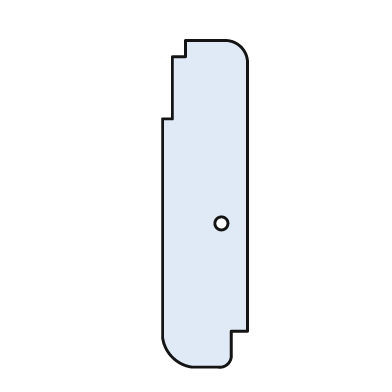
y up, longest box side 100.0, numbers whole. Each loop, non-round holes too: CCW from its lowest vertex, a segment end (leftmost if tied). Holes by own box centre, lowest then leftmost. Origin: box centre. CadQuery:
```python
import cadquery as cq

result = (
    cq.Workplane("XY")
    .moveTo(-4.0, -50.0)
    .lineTo(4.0, -50.0)
    .threePointArc((7.0, -49.0), (8.0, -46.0))
    .lineTo(8.0, -39.0)
    .lineTo(13.0, -39.0)
    .lineTo(13.0, 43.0)
    .threePointArc((11.0, 48.0), (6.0, 50.0))
    .lineTo(-6.0, 50.0)
    .lineTo(-6.0, 45.0)
    .lineTo(-10.0, 45.0)
    .lineTo(-10.0, 26.0)
    .lineTo(-13.0, 26.0)
    .lineTo(-13.0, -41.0)
    .threePointArc((-10.0, -47.0), (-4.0, -50.0))
    .close()
    .moveTo(5.0, -6.0)
    .circle(2.0)
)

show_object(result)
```